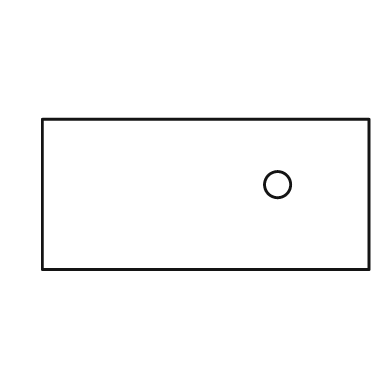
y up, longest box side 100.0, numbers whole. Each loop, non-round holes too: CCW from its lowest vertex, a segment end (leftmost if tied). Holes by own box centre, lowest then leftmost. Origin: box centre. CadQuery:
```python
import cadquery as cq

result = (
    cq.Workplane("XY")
    .moveTo(-50.0, -23.0)
    .lineTo(50.0, -23.0)
    .lineTo(50.0, 23.0)
    .lineTo(-50.0, 23.0)
    .close()
    .moveTo(22.0, 3.0)
    .circle(4.0)
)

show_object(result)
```